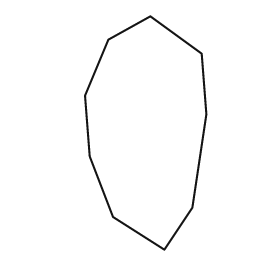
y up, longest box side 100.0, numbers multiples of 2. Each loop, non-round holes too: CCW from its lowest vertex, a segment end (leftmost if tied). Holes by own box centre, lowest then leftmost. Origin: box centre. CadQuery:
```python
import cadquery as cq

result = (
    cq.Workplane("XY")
    .moveTo(8.0, -50.0)
    .lineTo(20.0, -32.0)
    .lineTo(26.0, 8.0)
    .lineTo(24.0, 34.0)
    .lineTo(2.0, 50.0)
    .lineTo(-16.0, 40.0)
    .lineTo(-26.0, 16.0)
    .lineTo(-24.0, -10.0)
    .lineTo(-14.0, -36.0)
    .close()
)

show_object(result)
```